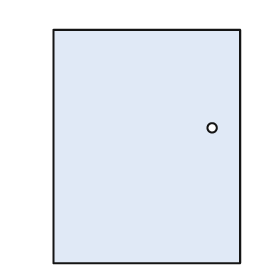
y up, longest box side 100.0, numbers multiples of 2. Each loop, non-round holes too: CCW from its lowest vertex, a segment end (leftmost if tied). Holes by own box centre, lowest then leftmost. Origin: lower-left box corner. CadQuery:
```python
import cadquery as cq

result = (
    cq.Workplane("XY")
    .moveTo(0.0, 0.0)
    .lineTo(80.0, 0.0)
    .lineTo(80.0, 100.0)
    .lineTo(0.0, 100.0)
    .close()
    .moveTo(68.0, 58.0)
    .circle(2.0)
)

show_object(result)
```